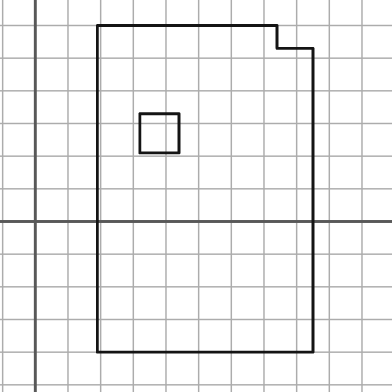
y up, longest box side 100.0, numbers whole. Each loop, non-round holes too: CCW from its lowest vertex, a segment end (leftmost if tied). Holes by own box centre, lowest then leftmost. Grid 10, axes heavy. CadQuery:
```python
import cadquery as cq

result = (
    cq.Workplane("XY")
    .moveTo(19.0, -40.0)
    .lineTo(85.0, -40.0)
    .lineTo(85.0, 53.0)
    .lineTo(74.0, 53.0)
    .lineTo(74.0, 60.0)
    .lineTo(19.0, 60.0)
    .close()
    .moveTo(32.0, 21.0)
    .lineTo(44.0, 21.0)
    .lineTo(44.0, 33.0)
    .lineTo(32.0, 33.0)
    .close()
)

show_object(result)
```